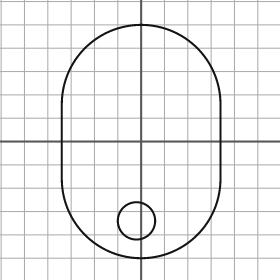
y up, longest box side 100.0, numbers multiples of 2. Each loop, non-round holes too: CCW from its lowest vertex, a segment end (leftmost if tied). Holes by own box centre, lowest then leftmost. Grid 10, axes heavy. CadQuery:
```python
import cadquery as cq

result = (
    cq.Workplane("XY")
    .moveTo(-34.0, -16.0)
    .threePointArc((0.0, -50.0), (34.0, -16.0))
    .lineTo(34.0, 16.0)
    .threePointArc((0.0, 50.0), (-34.0, 16.0))
    .close()
    .moveTo(-2.0, -34.0)
    .circle(8.0)
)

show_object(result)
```